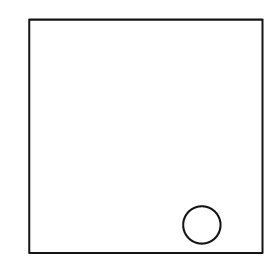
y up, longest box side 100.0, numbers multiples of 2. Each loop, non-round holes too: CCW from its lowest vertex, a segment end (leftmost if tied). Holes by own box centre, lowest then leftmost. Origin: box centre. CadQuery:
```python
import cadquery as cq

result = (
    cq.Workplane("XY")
    .moveTo(-50.0, -50.0)
    .lineTo(50.0, -50.0)
    .lineTo(50.0, 50.0)
    .lineTo(-50.0, 50.0)
    .close()
    .moveTo(24.0, -38.0)
    .circle(8.0)
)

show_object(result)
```